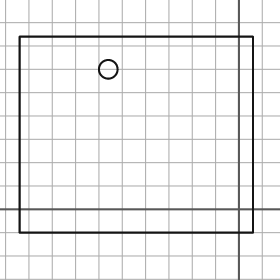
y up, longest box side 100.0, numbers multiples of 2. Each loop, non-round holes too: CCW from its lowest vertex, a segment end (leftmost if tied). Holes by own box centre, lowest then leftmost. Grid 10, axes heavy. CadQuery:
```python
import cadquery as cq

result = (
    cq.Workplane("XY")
    .moveTo(-94.0, -10.0)
    .lineTo(6.0, -10.0)
    .lineTo(6.0, 74.0)
    .lineTo(-94.0, 74.0)
    .close()
    .moveTo(-56.0, 60.0)
    .circle(4.0)
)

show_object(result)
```